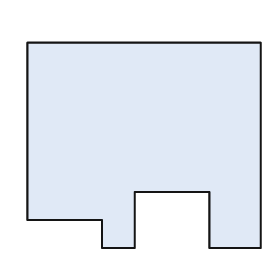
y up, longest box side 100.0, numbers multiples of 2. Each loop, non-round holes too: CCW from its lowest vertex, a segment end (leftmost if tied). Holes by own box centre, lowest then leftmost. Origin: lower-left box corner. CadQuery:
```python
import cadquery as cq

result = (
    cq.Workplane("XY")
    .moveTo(32.0, 0.0)
    .lineTo(46.0, 0.0)
    .lineTo(46.0, 24.0)
    .lineTo(78.0, 24.0)
    .lineTo(78.0, 0.0)
    .lineTo(100.0, 0.0)
    .lineTo(100.0, 88.0)
    .lineTo(0.0, 88.0)
    .lineTo(0.0, 12.0)
    .lineTo(32.0, 12.0)
    .close()
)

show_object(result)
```